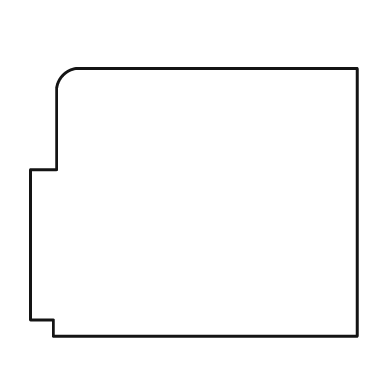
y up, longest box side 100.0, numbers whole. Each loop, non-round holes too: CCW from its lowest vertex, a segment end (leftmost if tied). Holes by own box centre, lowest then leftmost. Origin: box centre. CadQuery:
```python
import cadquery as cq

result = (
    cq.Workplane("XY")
    .moveTo(-43.0, -41.0)
    .lineTo(50.0, -41.0)
    .lineTo(50.0, 41.0)
    .lineTo(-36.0, 41.0)
    .threePointArc((-40.0, 39.0), (-42.0, 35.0))
    .lineTo(-42.0, 10.0)
    .lineTo(-50.0, 10.0)
    .lineTo(-50.0, -36.0)
    .lineTo(-43.0, -36.0)
    .close()
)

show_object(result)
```